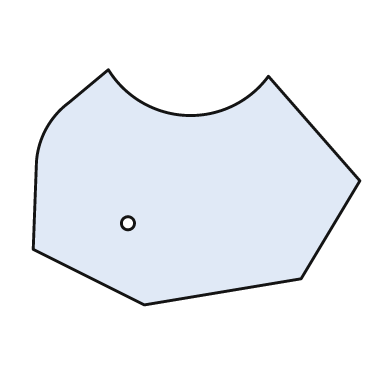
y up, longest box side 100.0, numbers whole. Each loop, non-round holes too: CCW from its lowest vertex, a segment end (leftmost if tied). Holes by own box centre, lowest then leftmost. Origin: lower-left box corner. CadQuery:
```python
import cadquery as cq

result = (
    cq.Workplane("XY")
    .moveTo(34.0, 0.0)
    .lineTo(82.0, 8.0)
    .lineTo(100.0, 38.0)
    .lineTo(72.0, 70.0)
    .threePointArc((47.0, 58.0), (23.0, 72.0))
    .lineTo(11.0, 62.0)
    .threePointArc((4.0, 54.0), (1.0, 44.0))
    .lineTo(0.0, 17.0)
    .close()
    .moveTo(29.0, 25.0)
    .circle(2.0)
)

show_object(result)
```